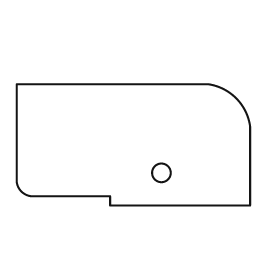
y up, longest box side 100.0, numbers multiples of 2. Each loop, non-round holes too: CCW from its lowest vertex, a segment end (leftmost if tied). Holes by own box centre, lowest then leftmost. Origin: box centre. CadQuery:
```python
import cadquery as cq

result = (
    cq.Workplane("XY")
    .moveTo(-10.0, -26.0)
    .lineTo(50.0, -26.0)
    .lineTo(50.0, 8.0)
    .threePointArc((44.0, 20.0), (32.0, 26.0))
    .lineTo(-50.0, 26.0)
    .lineTo(-50.0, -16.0)
    .threePointArc((-48.0, -20.0), (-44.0, -22.0))
    .lineTo(-10.0, -22.0)
    .close()
    .moveTo(12.0, -12.0)
    .circle(4.0)
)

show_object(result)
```